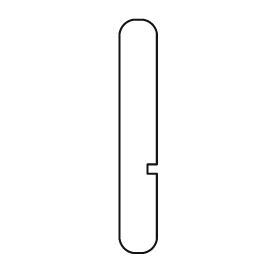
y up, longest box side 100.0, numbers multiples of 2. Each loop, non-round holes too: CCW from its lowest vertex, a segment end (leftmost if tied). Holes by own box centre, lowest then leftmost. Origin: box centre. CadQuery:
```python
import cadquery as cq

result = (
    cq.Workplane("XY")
    .moveTo(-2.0, -50.0)
    .lineTo(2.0, -50.0)
    .threePointArc((6.0, -48.0), (8.0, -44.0))
    .lineTo(8.0, -16.0)
    .lineTo(4.0, -16.0)
    .lineTo(4.0, -12.0)
    .lineTo(8.0, -12.0)
    .lineTo(8.0, 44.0)
    .threePointArc((6.0, 48.0), (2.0, 50.0))
    .lineTo(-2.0, 50.0)
    .threePointArc((-6.0, 48.0), (-8.0, 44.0))
    .lineTo(-8.0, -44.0)
    .threePointArc((-6.0, -48.0), (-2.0, -50.0))
    .close()
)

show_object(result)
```